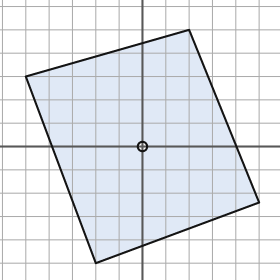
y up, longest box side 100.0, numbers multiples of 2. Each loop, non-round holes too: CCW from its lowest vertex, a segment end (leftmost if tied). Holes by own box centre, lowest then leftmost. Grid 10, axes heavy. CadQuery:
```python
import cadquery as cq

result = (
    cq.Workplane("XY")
    .moveTo(-20.0, -50.0)
    .lineTo(50.0, -24.0)
    .lineTo(20.0, 50.0)
    .lineTo(-50.0, 30.0)
    .close()
    .moveTo(0.0, 0.0)
    .circle(2.0)
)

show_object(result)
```